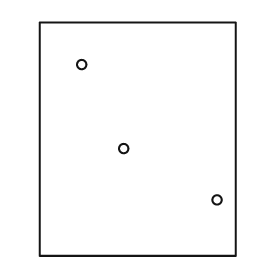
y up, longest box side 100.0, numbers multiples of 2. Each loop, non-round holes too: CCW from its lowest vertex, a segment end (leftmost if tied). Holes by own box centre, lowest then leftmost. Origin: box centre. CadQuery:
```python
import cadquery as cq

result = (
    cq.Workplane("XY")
    .moveTo(-42.0, -50.0)
    .lineTo(42.0, -50.0)
    .lineTo(42.0, 50.0)
    .lineTo(-42.0, 50.0)
    .close()
    .moveTo(34.0, -26.0)
    .circle(2.0)
    .moveTo(-6.0, -4.0)
    .circle(2.0)
    .moveTo(-24.0, 32.0)
    .circle(2.0)
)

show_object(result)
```